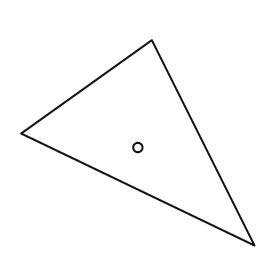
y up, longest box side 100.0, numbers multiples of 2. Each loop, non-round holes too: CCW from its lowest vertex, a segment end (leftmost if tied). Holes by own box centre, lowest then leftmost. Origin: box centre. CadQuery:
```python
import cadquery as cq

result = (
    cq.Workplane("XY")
    .moveTo(50.0, -44.0)
    .lineTo(6.0, 44.0)
    .lineTo(-50.0, 4.0)
    .close()
    .moveTo(0.0, -2.0)
    .circle(2.0)
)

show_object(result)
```